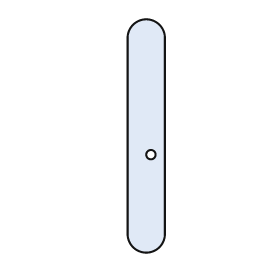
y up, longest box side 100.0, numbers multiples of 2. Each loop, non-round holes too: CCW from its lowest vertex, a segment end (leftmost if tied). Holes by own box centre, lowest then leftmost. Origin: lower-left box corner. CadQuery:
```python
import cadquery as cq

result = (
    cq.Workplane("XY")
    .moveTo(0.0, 8.0)
    .threePointArc((8.0, 0.0), (16.0, 8.0))
    .lineTo(16.0, 92.0)
    .threePointArc((8.0, 100.0), (0.0, 92.0))
    .close()
    .moveTo(10.0, 42.0)
    .circle(2.0)
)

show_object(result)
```